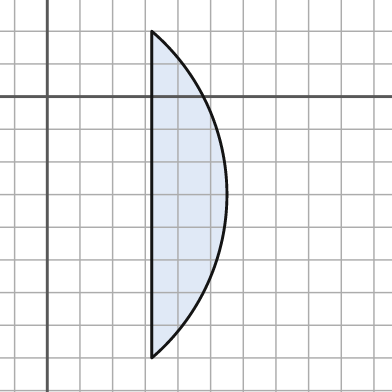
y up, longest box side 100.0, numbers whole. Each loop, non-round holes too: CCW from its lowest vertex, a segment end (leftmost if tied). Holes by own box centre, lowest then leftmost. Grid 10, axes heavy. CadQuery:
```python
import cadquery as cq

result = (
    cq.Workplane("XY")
    .moveTo(32.0, -80.0)
    .threePointArc((55.0, -30.0), (32.0, 20.0))
    .close()
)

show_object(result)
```